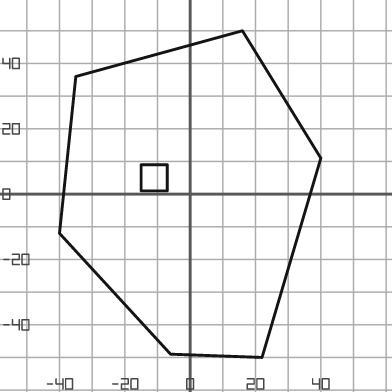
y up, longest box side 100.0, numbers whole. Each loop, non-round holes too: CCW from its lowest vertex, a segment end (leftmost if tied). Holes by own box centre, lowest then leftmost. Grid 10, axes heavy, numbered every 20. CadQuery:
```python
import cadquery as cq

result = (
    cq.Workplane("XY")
    .moveTo(22.0, -50.0)
    .lineTo(40.0, 11.0)
    .lineTo(16.0, 50.0)
    .lineTo(-35.0, 36.0)
    .lineTo(-40.0, -12.0)
    .lineTo(-6.0, -49.0)
    .close()
    .moveTo(-15.0, 1.0)
    .lineTo(-7.0, 1.0)
    .lineTo(-7.0, 9.0)
    .lineTo(-15.0, 9.0)
    .close()
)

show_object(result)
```